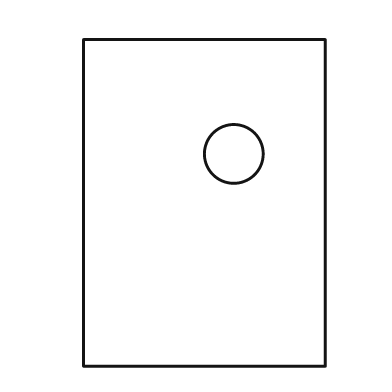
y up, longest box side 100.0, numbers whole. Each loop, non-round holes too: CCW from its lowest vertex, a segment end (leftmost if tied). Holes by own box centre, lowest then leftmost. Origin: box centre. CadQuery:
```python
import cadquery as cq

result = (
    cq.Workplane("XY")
    .moveTo(-37.0, -50.0)
    .lineTo(37.0, -50.0)
    .lineTo(37.0, 50.0)
    .lineTo(-37.0, 50.0)
    .close()
    .moveTo(9.0, 15.0)
    .circle(9.0)
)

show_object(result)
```